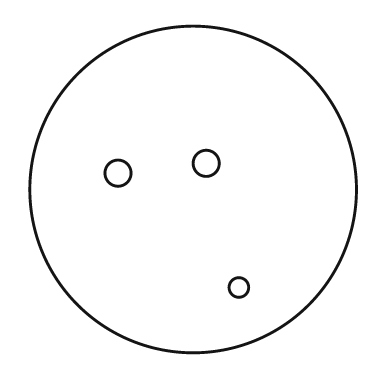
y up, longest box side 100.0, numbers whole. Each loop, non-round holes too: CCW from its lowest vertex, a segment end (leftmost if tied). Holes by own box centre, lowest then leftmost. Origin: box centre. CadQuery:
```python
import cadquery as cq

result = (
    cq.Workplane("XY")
    .moveTo(0.0, 0.0)
    .circle(50.0)
    .moveTo(14.0, -30.0)
    .circle(3.0)
    .moveTo(-23.0, 5.0)
    .circle(4.0)
    .moveTo(4.0, 8.0)
    .circle(4.0)
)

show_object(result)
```